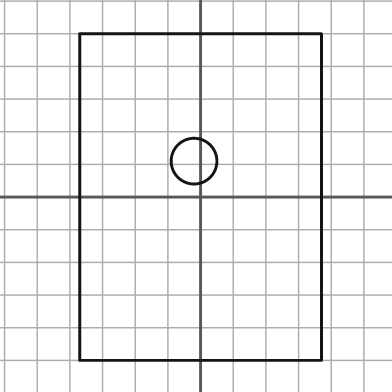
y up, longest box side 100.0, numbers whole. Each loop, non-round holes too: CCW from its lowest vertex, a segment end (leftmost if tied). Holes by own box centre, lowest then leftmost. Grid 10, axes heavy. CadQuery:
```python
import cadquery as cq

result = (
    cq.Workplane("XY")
    .moveTo(-37.0, -50.0)
    .lineTo(37.0, -50.0)
    .lineTo(37.0, 50.0)
    .lineTo(-37.0, 50.0)
    .close()
    .moveTo(-2.0, 11.0)
    .circle(7.0)
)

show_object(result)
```